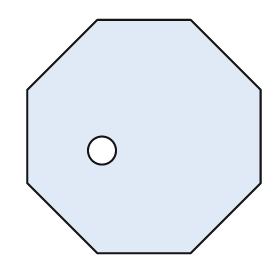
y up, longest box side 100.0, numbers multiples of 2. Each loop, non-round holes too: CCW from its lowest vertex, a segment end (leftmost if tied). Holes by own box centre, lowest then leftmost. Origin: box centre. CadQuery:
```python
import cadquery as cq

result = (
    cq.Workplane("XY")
    .moveTo(-20.0, -50.0)
    .lineTo(20.0, -50.0)
    .lineTo(50.0, -20.0)
    .lineTo(50.0, 20.0)
    .lineTo(20.0, 50.0)
    .lineTo(-20.0, 50.0)
    .lineTo(-50.0, 20.0)
    .lineTo(-50.0, -20.0)
    .close()
    .moveTo(-18.0, -6.0)
    .circle(6.0)
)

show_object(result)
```